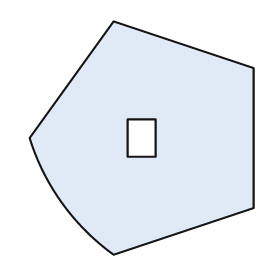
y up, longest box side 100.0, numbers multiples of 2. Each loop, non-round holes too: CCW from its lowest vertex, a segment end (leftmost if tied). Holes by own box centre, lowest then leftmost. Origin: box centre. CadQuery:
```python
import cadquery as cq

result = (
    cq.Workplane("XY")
    .moveTo(-12.0, -50.0)
    .lineTo(48.0, -30.0)
    .lineTo(48.0, 30.0)
    .lineTo(-12.0, 50.0)
    .lineTo(-48.0, 0.0)
    .threePointArc((-34.0, -28.0), (-12.0, -50.0))
    .close()
    .moveTo(-6.0, -8.0)
    .lineTo(6.0, -8.0)
    .lineTo(6.0, 8.0)
    .lineTo(-6.0, 8.0)
    .close()
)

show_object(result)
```